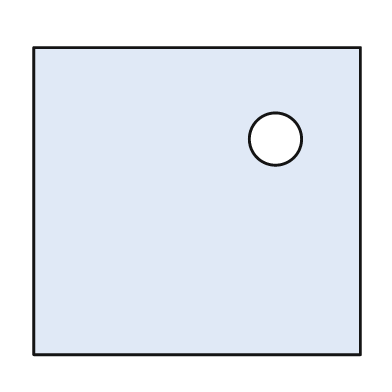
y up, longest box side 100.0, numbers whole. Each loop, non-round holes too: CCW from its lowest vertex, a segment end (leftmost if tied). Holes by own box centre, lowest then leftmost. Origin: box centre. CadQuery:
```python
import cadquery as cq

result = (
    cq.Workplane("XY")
    .moveTo(-50.0, -47.0)
    .lineTo(50.0, -47.0)
    .lineTo(50.0, 47.0)
    .lineTo(-50.0, 47.0)
    .close()
    .moveTo(24.0, 19.0)
    .circle(8.0)
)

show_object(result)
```